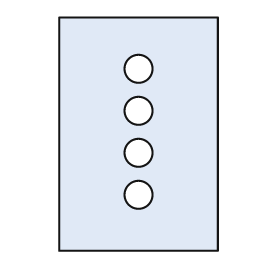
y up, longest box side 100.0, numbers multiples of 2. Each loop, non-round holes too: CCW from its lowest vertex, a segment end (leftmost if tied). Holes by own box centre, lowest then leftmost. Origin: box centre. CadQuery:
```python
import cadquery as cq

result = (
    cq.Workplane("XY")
    .moveTo(-34.0, -50.0)
    .lineTo(34.0, -50.0)
    .lineTo(34.0, 50.0)
    .lineTo(-34.0, 50.0)
    .close()
    .moveTo(0.0, -26.0)
    .circle(6.0)
    .moveTo(0.0, -8.0)
    .circle(6.0)
    .moveTo(0.0, 10.0)
    .circle(6.0)
    .moveTo(0.0, 28.0)
    .circle(6.0)
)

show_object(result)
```